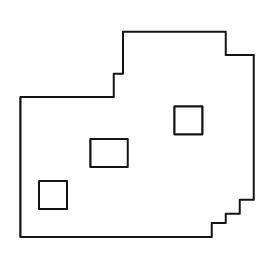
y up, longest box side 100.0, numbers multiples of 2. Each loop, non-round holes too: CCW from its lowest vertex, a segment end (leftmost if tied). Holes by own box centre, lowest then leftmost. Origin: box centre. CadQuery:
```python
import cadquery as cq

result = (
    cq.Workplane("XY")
    .moveTo(-50.0, -44.0)
    .lineTo(32.0, -44.0)
    .lineTo(32.0, -38.0)
    .lineTo(38.0, -38.0)
    .lineTo(38.0, -34.0)
    .lineTo(44.0, -34.0)
    .lineTo(44.0, -28.0)
    .lineTo(50.0, -28.0)
    .lineTo(50.0, 34.0)
    .lineTo(38.0, 34.0)
    .lineTo(38.0, 44.0)
    .lineTo(-6.0, 44.0)
    .lineTo(-6.0, 26.0)
    .lineTo(-10.0, 26.0)
    .lineTo(-10.0, 16.0)
    .lineTo(-50.0, 16.0)
    .close()
    .moveTo(-42.0, -32.0)
    .lineTo(-30.0, -32.0)
    .lineTo(-30.0, -20.0)
    .lineTo(-42.0, -20.0)
    .close()
    .moveTo(-20.0, -14.0)
    .lineTo(-4.0, -14.0)
    .lineTo(-4.0, -2.0)
    .lineTo(-20.0, -2.0)
    .close()
    .moveTo(16.0, 0.0)
    .lineTo(28.0, 0.0)
    .lineTo(28.0, 12.0)
    .lineTo(16.0, 12.0)
    .close()
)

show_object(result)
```